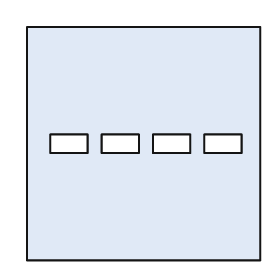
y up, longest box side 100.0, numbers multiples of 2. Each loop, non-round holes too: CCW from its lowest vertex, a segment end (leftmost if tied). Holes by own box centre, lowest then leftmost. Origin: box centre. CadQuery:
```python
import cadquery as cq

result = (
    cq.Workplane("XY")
    .moveTo(-50.0, -50.0)
    .lineTo(50.0, -50.0)
    .lineTo(50.0, 50.0)
    .lineTo(-50.0, 50.0)
    .close()
    .moveTo(-40.0, -4.0)
    .lineTo(-24.0, -4.0)
    .lineTo(-24.0, 4.0)
    .lineTo(-40.0, 4.0)
    .close()
    .moveTo(-18.0, -4.0)
    .lineTo(-2.0, -4.0)
    .lineTo(-2.0, 4.0)
    .lineTo(-18.0, 4.0)
    .close()
    .moveTo(4.0, -4.0)
    .lineTo(20.0, -4.0)
    .lineTo(20.0, 4.0)
    .lineTo(4.0, 4.0)
    .close()
    .moveTo(26.0, -4.0)
    .lineTo(42.0, -4.0)
    .lineTo(42.0, 4.0)
    .lineTo(26.0, 4.0)
    .close()
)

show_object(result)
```